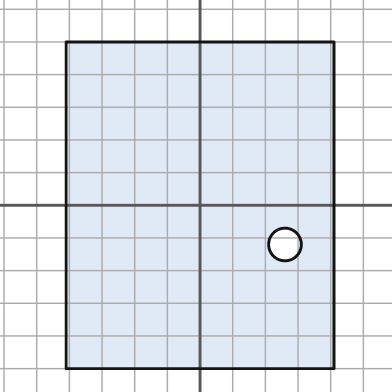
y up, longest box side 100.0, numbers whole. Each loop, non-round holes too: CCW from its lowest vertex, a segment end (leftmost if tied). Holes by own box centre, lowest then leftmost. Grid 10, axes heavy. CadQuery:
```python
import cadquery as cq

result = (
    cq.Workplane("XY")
    .moveTo(-41.0, -50.0)
    .lineTo(41.0, -50.0)
    .lineTo(41.0, 50.0)
    .lineTo(-41.0, 50.0)
    .close()
    .moveTo(26.0, -12.0)
    .circle(5.0)
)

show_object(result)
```